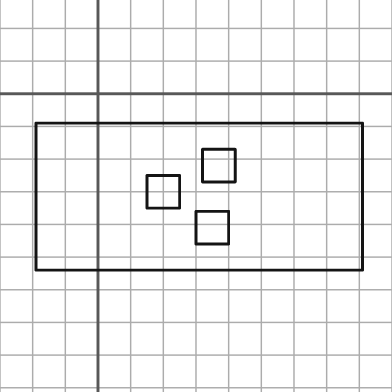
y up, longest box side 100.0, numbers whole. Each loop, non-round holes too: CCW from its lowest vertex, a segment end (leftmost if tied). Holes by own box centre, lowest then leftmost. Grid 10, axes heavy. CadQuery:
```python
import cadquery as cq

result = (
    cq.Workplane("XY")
    .moveTo(-19.0, -54.0)
    .lineTo(81.0, -54.0)
    .lineTo(81.0, -9.0)
    .lineTo(-19.0, -9.0)
    .close()
    .moveTo(30.0, -46.0)
    .lineTo(40.0, -46.0)
    .lineTo(40.0, -36.0)
    .lineTo(30.0, -36.0)
    .close()
    .moveTo(15.0, -35.0)
    .lineTo(25.0, -35.0)
    .lineTo(25.0, -25.0)
    .lineTo(15.0, -25.0)
    .close()
    .moveTo(32.0, -27.0)
    .lineTo(42.0, -27.0)
    .lineTo(42.0, -17.0)
    .lineTo(32.0, -17.0)
    .close()
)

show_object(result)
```